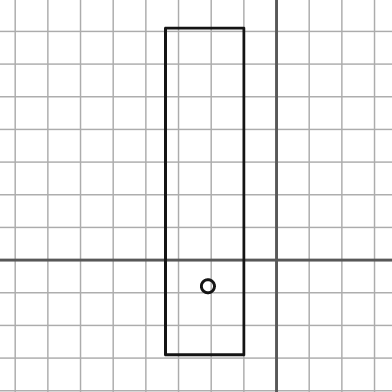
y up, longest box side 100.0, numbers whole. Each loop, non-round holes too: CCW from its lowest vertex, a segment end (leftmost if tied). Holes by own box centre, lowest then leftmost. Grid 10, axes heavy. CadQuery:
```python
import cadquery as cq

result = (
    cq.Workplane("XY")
    .moveTo(-34.0, -29.0)
    .lineTo(-10.0, -29.0)
    .lineTo(-10.0, 71.0)
    .lineTo(-34.0, 71.0)
    .close()
    .moveTo(-21.0, -8.0)
    .circle(2.0)
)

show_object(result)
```